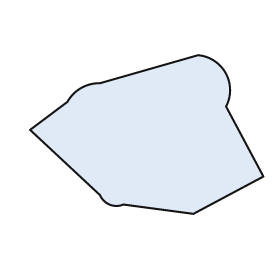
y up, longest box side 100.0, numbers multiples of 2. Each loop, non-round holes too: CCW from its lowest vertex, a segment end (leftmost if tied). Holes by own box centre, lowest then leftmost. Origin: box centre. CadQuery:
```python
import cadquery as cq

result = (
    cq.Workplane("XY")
    .moveTo(20.0, -34.0)
    .lineTo(50.0, -18.0)
    .lineTo(34.0, 12.0)
    .threePointArc((34.0, 26.0), (22.0, 34.0))
    .lineTo(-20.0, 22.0)
    .threePointArc((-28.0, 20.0), (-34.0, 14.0))
    .lineTo(-50.0, 2.0)
    .lineTo(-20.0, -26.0)
    .threePointArc((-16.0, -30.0), (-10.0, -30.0))
    .close()
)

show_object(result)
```